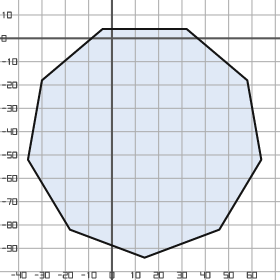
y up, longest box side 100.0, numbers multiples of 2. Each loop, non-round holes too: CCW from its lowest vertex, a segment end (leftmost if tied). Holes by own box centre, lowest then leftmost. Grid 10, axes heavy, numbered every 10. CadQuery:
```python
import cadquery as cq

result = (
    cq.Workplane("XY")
    .moveTo(14.0, -94.0)
    .lineTo(46.0, -82.0)
    .lineTo(64.0, -52.0)
    .lineTo(58.0, -18.0)
    .lineTo(32.0, 4.0)
    .lineTo(-4.0, 4.0)
    .lineTo(-30.0, -18.0)
    .lineTo(-36.0, -52.0)
    .lineTo(-18.0, -82.0)
    .close()
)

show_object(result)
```